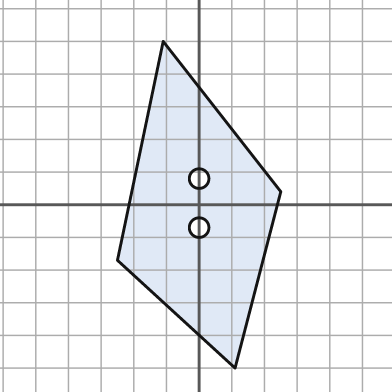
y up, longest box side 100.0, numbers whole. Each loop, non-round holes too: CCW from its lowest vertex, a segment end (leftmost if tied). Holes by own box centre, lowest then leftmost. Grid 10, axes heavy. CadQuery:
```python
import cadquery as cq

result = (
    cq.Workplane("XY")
    .moveTo(11.0, -50.0)
    .lineTo(25.0, 4.0)
    .lineTo(-11.0, 50.0)
    .lineTo(-25.0, -17.0)
    .close()
    .moveTo(0.0, -7.0)
    .circle(3.0)
    .moveTo(0.0, 8.0)
    .circle(3.0)
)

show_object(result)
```